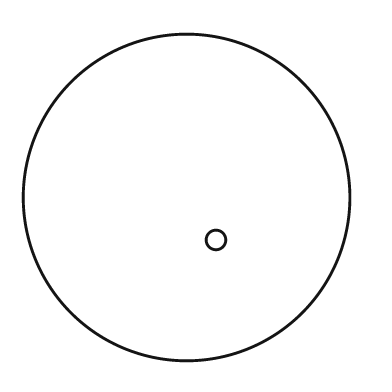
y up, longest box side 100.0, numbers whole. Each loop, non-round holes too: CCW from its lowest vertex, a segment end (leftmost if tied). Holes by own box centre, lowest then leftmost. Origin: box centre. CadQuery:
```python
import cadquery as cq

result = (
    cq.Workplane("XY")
    .moveTo(0.0, 0.0)
    .circle(50.0)
    .moveTo(9.0, -13.0)
    .circle(3.0)
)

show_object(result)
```